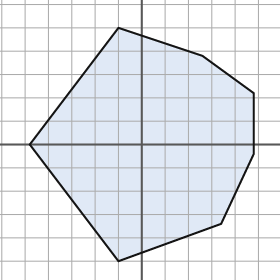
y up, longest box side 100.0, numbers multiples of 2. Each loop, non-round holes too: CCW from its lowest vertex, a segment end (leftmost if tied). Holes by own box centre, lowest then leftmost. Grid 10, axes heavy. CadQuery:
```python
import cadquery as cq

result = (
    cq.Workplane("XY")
    .moveTo(-10.0, -50.0)
    .lineTo(34.0, -34.0)
    .lineTo(48.0, -4.0)
    .lineTo(48.0, 22.0)
    .lineTo(26.0, 38.0)
    .lineTo(-10.0, 50.0)
    .lineTo(-48.0, 0.0)
    .close()
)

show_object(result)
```